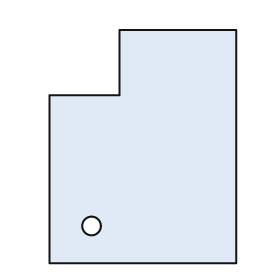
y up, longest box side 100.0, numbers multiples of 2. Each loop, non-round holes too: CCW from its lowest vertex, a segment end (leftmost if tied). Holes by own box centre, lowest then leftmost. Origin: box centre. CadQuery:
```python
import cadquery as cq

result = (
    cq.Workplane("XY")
    .moveTo(-40.0, -50.0)
    .lineTo(40.0, -50.0)
    .lineTo(40.0, 50.0)
    .lineTo(-10.0, 50.0)
    .lineTo(-10.0, 22.0)
    .lineTo(-40.0, 22.0)
    .close()
    .moveTo(-22.0, -34.0)
    .circle(4.0)
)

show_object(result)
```